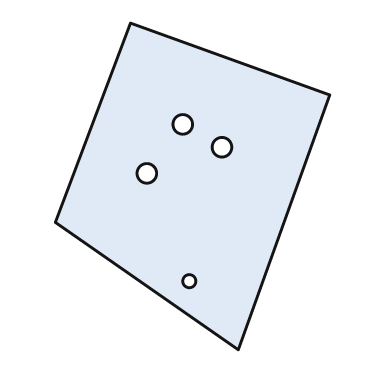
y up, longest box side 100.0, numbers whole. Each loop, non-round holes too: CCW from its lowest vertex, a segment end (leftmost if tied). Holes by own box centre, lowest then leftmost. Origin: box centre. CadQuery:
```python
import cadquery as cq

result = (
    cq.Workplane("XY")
    .moveTo(14.0, -50.0)
    .lineTo(42.0, 28.0)
    .lineTo(-19.0, 50.0)
    .lineTo(-42.0, -11.0)
    .close()
    .moveTo(-1.0, -29.0)
    .circle(2.0)
    .moveTo(-14.0, 4.0)
    .circle(3.0)
    .moveTo(9.0, 12.0)
    .circle(3.0)
    .moveTo(-3.0, 19.0)
    .circle(3.0)
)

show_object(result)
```